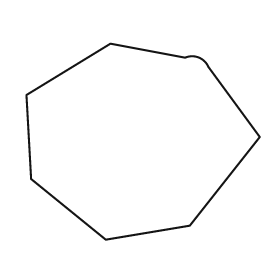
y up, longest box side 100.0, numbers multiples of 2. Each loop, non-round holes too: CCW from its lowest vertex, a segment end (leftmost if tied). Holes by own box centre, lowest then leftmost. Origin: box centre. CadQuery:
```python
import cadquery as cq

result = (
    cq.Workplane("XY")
    .moveTo(-16.0, -42.0)
    .lineTo(20.0, -36.0)
    .lineTo(50.0, 2.0)
    .lineTo(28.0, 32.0)
    .threePointArc((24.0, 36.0), (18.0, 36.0))
    .lineTo(-14.0, 42.0)
    .lineTo(-50.0, 20.0)
    .lineTo(-48.0, -16.0)
    .close()
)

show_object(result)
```